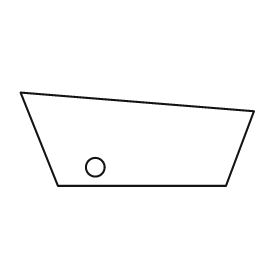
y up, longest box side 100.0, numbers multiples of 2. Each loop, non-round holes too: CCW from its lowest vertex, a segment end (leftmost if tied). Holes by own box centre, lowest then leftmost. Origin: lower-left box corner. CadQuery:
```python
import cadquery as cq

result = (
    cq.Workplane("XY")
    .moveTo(16.0, 0.0)
    .lineTo(88.0, 0.0)
    .lineTo(100.0, 32.0)
    .lineTo(0.0, 40.0)
    .close()
    .moveTo(32.0, 8.0)
    .circle(4.0)
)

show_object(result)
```